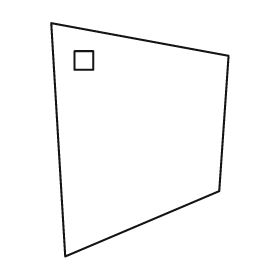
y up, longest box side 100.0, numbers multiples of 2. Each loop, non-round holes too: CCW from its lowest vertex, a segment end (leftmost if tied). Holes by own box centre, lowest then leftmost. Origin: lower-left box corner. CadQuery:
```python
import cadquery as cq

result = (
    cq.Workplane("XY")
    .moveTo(6.0, 0.0)
    .lineTo(72.0, 28.0)
    .lineTo(76.0, 86.0)
    .lineTo(0.0, 100.0)
    .close()
    .moveTo(10.0, 80.0)
    .lineTo(18.0, 80.0)
    .lineTo(18.0, 88.0)
    .lineTo(10.0, 88.0)
    .close()
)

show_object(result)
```